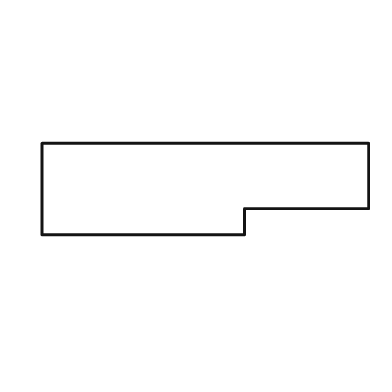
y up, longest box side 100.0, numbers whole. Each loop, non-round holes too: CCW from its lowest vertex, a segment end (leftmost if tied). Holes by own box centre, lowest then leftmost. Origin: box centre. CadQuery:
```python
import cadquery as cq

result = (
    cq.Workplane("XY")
    .moveTo(-50.0, -14.0)
    .lineTo(12.0, -14.0)
    .lineTo(12.0, -6.0)
    .lineTo(50.0, -6.0)
    .lineTo(50.0, 14.0)
    .lineTo(-50.0, 14.0)
    .close()
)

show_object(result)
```